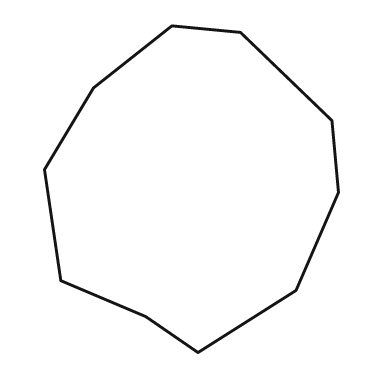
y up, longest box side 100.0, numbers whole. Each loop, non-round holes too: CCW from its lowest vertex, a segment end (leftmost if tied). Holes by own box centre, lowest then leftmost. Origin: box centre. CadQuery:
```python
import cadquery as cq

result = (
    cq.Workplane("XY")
    .moveTo(2.0, -50.0)
    .lineTo(32.0, -31.0)
    .lineTo(45.0, -1.0)
    .lineTo(43.0, 21.0)
    .lineTo(15.0, 48.0)
    .lineTo(-6.0, 50.0)
    .lineTo(-30.0, 31.0)
    .lineTo(-45.0, 6.0)
    .lineTo(-40.0, -28.0)
    .lineTo(-14.0, -39.0)
    .close()
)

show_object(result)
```